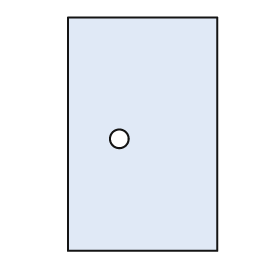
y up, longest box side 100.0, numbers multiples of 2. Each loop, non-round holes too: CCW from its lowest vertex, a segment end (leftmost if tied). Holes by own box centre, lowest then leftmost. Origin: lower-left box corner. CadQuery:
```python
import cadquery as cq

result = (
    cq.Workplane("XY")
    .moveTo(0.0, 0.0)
    .lineTo(64.0, 0.0)
    .lineTo(64.0, 100.0)
    .lineTo(0.0, 100.0)
    .close()
    .moveTo(22.0, 48.0)
    .circle(4.0)
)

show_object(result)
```